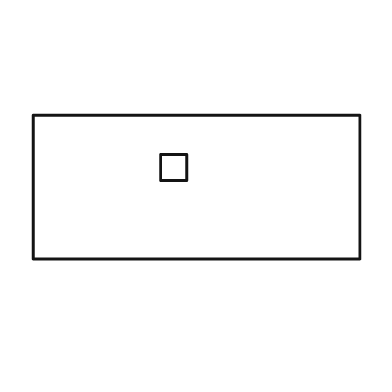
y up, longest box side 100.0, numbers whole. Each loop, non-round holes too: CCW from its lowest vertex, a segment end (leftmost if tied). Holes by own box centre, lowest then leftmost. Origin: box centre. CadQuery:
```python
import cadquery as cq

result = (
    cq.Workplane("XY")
    .moveTo(-50.0, -22.0)
    .lineTo(50.0, -22.0)
    .lineTo(50.0, 22.0)
    .lineTo(-50.0, 22.0)
    .close()
    .moveTo(-11.0, 2.0)
    .lineTo(-3.0, 2.0)
    .lineTo(-3.0, 10.0)
    .lineTo(-11.0, 10.0)
    .close()
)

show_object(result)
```